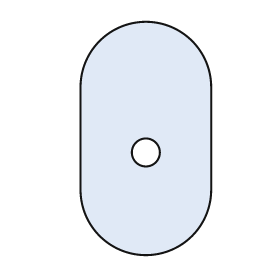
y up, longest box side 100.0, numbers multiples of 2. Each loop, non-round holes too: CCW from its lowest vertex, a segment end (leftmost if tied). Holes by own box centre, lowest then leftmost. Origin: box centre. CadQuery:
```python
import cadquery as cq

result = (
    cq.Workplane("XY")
    .moveTo(-28.0, -22.0)
    .threePointArc((0.0, -50.0), (28.0, -22.0))
    .lineTo(28.0, 22.0)
    .threePointArc((0.0, 50.0), (-28.0, 22.0))
    .close()
    .moveTo(0.0, -6.0)
    .circle(6.0)
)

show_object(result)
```